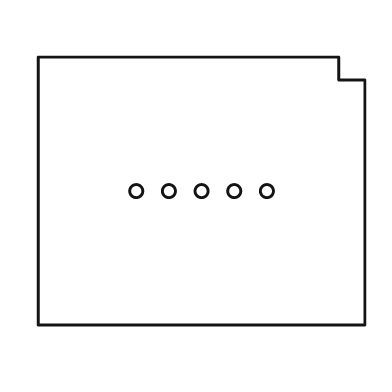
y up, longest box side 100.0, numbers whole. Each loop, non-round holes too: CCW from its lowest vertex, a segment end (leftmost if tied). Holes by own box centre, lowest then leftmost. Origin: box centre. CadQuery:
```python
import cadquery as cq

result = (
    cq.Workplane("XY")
    .moveTo(-50.0, -41.0)
    .lineTo(50.0, -41.0)
    .lineTo(50.0, 34.0)
    .lineTo(42.0, 34.0)
    .lineTo(42.0, 41.0)
    .lineTo(-50.0, 41.0)
    .close()
    .moveTo(-20.0, 0.0)
    .circle(2.0)
    .moveTo(-10.0, 0.0)
    .circle(2.0)
    .moveTo(0.0, 0.0)
    .circle(2.0)
    .moveTo(10.0, 0.0)
    .circle(2.0)
    .moveTo(20.0, 0.0)
    .circle(2.0)
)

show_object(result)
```